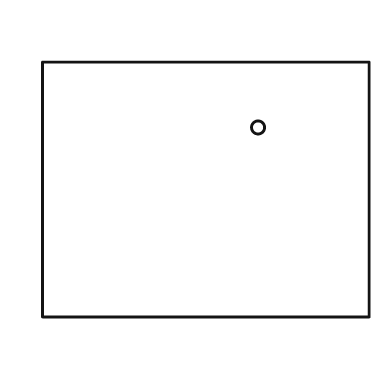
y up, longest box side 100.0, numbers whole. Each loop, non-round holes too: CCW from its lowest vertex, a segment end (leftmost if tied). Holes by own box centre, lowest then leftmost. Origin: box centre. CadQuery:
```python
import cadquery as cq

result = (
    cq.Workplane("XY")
    .moveTo(-50.0, -39.0)
    .lineTo(50.0, -39.0)
    .lineTo(50.0, 39.0)
    .lineTo(-50.0, 39.0)
    .close()
    .moveTo(16.0, 19.0)
    .circle(2.0)
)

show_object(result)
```